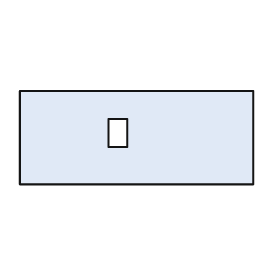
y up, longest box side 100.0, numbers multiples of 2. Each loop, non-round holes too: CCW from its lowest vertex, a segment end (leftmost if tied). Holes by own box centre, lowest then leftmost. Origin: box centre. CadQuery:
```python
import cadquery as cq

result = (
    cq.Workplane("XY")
    .moveTo(-50.0, -20.0)
    .lineTo(50.0, -20.0)
    .lineTo(50.0, 20.0)
    .lineTo(-50.0, 20.0)
    .close()
    .moveTo(-12.0, -4.0)
    .lineTo(-4.0, -4.0)
    .lineTo(-4.0, 8.0)
    .lineTo(-12.0, 8.0)
    .close()
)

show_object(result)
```